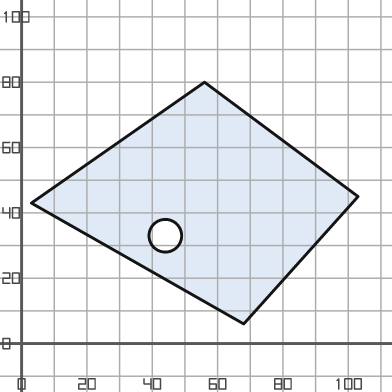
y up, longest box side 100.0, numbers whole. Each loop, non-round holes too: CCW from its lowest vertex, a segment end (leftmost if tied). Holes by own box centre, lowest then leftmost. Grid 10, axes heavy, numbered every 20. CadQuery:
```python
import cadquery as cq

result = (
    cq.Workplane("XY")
    .moveTo(68.0, 6.0)
    .lineTo(103.0, 45.0)
    .lineTo(56.0, 80.0)
    .lineTo(3.0, 43.0)
    .close()
    .moveTo(44.0, 33.0)
    .circle(5.0)
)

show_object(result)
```